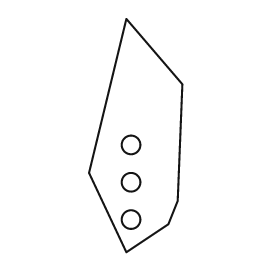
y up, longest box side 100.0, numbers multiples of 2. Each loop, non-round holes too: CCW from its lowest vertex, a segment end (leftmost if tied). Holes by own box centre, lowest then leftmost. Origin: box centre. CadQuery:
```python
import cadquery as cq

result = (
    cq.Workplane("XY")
    .moveTo(-4.0, -50.0)
    .lineTo(14.0, -38.0)
    .lineTo(18.0, -28.0)
    .lineTo(20.0, 22.0)
    .lineTo(-4.0, 50.0)
    .lineTo(-20.0, -16.0)
    .close()
    .moveTo(-2.0, -36.0)
    .circle(4.0)
    .moveTo(-2.0, -20.0)
    .circle(4.0)
    .moveTo(-2.0, -4.0)
    .circle(4.0)
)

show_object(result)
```